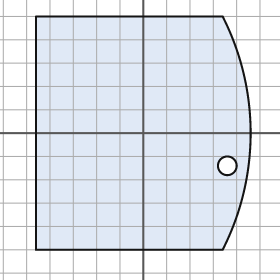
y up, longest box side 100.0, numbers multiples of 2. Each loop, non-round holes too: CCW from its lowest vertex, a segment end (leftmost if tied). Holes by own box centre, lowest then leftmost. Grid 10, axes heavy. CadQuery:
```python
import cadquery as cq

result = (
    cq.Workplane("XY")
    .moveTo(-46.0, -50.0)
    .lineTo(34.0, -50.0)
    .threePointArc((46.0, 0.0), (34.0, 50.0))
    .lineTo(-46.0, 50.0)
    .close()
    .moveTo(36.0, -14.0)
    .circle(4.0)
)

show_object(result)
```